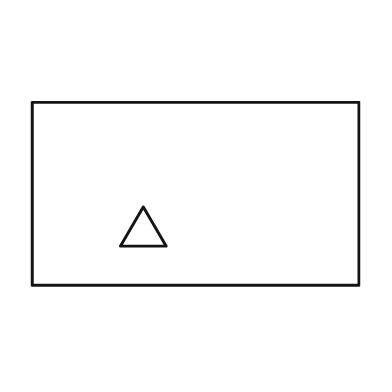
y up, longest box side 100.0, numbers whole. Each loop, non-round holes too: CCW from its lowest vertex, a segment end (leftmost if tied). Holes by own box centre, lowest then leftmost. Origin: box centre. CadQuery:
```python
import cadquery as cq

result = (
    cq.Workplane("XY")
    .moveTo(-50.0, -28.0)
    .lineTo(50.0, -28.0)
    .lineTo(50.0, 28.0)
    .lineTo(-50.0, 28.0)
    .close()
    .moveTo(-23.0, -16.0)
    .lineTo(-9.0, -16.0)
    .lineTo(-16.0, -4.0)
    .close()
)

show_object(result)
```